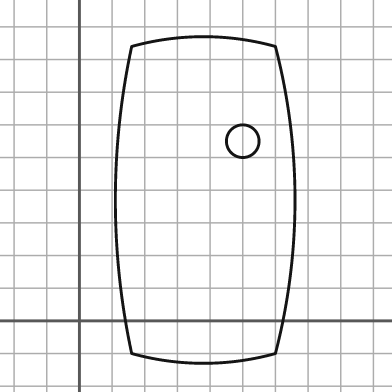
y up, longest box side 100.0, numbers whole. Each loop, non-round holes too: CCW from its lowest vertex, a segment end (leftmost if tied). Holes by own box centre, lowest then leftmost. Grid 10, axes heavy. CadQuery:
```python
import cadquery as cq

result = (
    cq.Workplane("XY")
    .moveTo(16.0, -10.0)
    .threePointArc((38.0, -13.0), (60.0, -10.0))
    .threePointArc((66.0, 37.0), (60.0, 84.0))
    .threePointArc((38.0, 87.0), (16.0, 84.0))
    .threePointArc((11.0, 37.0), (16.0, -10.0))
    .close()
    .moveTo(50.0, 55.0)
    .circle(5.0)
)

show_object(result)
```